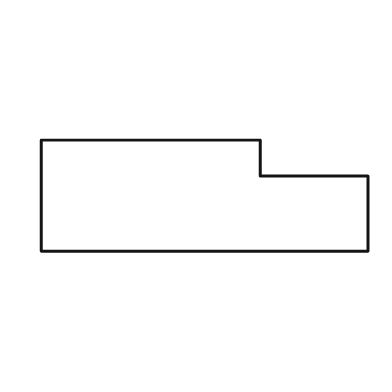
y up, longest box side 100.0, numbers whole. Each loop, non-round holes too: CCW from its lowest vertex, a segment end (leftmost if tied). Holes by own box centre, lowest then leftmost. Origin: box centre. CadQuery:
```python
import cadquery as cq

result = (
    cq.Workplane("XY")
    .moveTo(-50.0, -17.0)
    .lineTo(50.0, -17.0)
    .lineTo(50.0, 6.0)
    .lineTo(17.0, 6.0)
    .lineTo(17.0, 17.0)
    .lineTo(-50.0, 17.0)
    .close()
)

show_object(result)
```